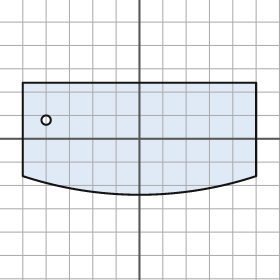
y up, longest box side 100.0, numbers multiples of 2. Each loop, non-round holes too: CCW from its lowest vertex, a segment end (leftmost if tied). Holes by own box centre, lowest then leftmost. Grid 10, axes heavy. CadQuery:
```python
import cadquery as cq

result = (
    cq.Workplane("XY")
    .moveTo(-50.0, -16.0)
    .threePointArc((0.0, -24.0), (50.0, -16.0))
    .lineTo(50.0, 24.0)
    .lineTo(-50.0, 24.0)
    .close()
    .moveTo(-40.0, 8.0)
    .circle(2.0)
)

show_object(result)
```